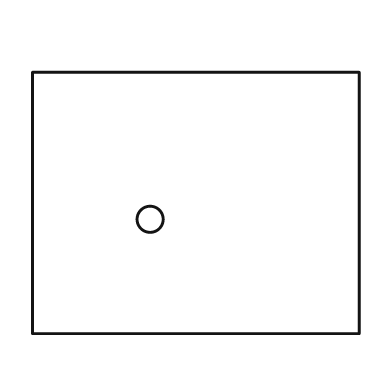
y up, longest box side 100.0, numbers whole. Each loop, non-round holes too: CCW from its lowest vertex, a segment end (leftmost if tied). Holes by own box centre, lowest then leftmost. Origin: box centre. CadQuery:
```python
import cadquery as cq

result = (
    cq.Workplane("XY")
    .moveTo(-50.0, -40.0)
    .lineTo(50.0, -40.0)
    .lineTo(50.0, 40.0)
    .lineTo(-50.0, 40.0)
    .close()
    .moveTo(-14.0, -5.0)
    .circle(4.0)
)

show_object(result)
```